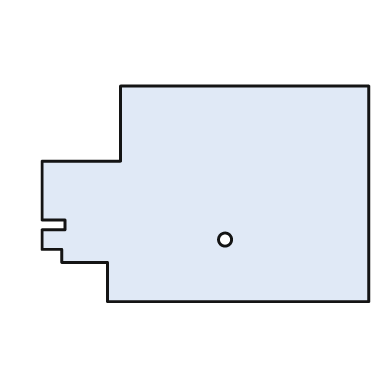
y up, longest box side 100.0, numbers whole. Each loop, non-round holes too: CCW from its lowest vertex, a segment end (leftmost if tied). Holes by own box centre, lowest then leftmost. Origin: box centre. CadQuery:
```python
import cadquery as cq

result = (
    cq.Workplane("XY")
    .moveTo(-30.0, -33.0)
    .lineTo(50.0, -33.0)
    .lineTo(50.0, 33.0)
    .lineTo(-26.0, 33.0)
    .lineTo(-26.0, 10.0)
    .lineTo(-50.0, 10.0)
    .lineTo(-50.0, -8.0)
    .lineTo(-43.0, -8.0)
    .lineTo(-43.0, -11.0)
    .lineTo(-50.0, -11.0)
    .lineTo(-50.0, -17.0)
    .lineTo(-44.0, -17.0)
    .lineTo(-44.0, -21.0)
    .lineTo(-30.0, -21.0)
    .close()
    .moveTo(6.0, -14.0)
    .circle(2.0)
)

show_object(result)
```